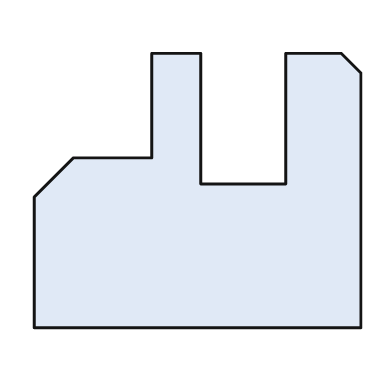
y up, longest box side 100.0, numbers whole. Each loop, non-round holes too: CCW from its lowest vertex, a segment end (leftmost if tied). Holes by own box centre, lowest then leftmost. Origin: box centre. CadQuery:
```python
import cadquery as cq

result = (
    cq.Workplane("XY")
    .moveTo(-50.0, -42.0)
    .lineTo(50.0, -42.0)
    .lineTo(50.0, 36.0)
    .lineTo(44.0, 42.0)
    .lineTo(27.0, 42.0)
    .lineTo(27.0, 2.0)
    .lineTo(1.0, 2.0)
    .lineTo(1.0, 42.0)
    .lineTo(-14.0, 42.0)
    .lineTo(-14.0, 10.0)
    .lineTo(-38.0, 10.0)
    .lineTo(-50.0, -2.0)
    .close()
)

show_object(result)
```